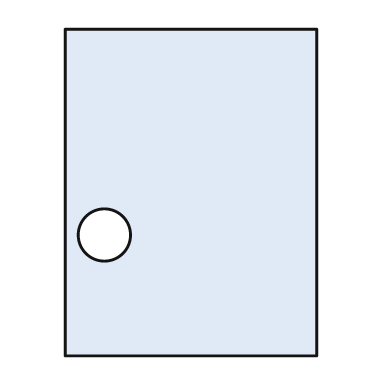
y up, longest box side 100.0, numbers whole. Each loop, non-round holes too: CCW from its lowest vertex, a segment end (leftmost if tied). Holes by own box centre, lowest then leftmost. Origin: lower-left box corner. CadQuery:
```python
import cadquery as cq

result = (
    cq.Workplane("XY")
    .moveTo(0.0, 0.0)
    .lineTo(77.0, 0.0)
    .lineTo(77.0, 100.0)
    .lineTo(0.0, 100.0)
    .close()
    .moveTo(12.0, 37.0)
    .circle(8.0)
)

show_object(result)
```